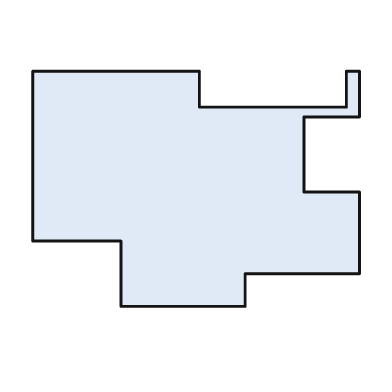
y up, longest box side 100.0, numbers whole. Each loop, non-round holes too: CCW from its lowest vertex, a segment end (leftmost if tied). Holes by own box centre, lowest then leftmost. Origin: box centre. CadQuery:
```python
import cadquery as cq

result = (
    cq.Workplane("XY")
    .moveTo(-23.0, -36.0)
    .lineTo(15.0, -36.0)
    .lineTo(15.0, -26.0)
    .lineTo(50.0, -26.0)
    .lineTo(50.0, -1.0)
    .lineTo(33.0, -1.0)
    .lineTo(33.0, 22.0)
    .lineTo(50.0, 22.0)
    .lineTo(50.0, 36.0)
    .lineTo(46.0, 36.0)
    .lineTo(46.0, 25.0)
    .lineTo(1.0, 25.0)
    .lineTo(1.0, 36.0)
    .lineTo(-50.0, 36.0)
    .lineTo(-50.0, -16.0)
    .lineTo(-23.0, -16.0)
    .close()
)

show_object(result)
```